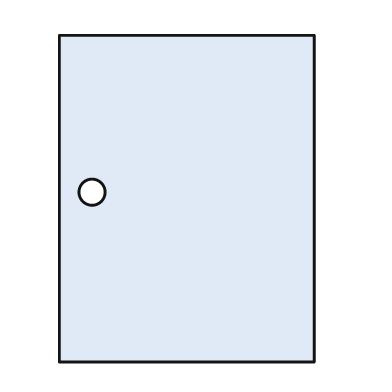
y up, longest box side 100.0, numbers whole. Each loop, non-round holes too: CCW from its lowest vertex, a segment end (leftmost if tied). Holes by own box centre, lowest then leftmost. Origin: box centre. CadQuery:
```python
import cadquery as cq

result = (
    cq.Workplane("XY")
    .moveTo(-39.0, -50.0)
    .lineTo(39.0, -50.0)
    .lineTo(39.0, 50.0)
    .lineTo(-39.0, 50.0)
    .close()
    .moveTo(-29.0, 2.0)
    .circle(4.0)
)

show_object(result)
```